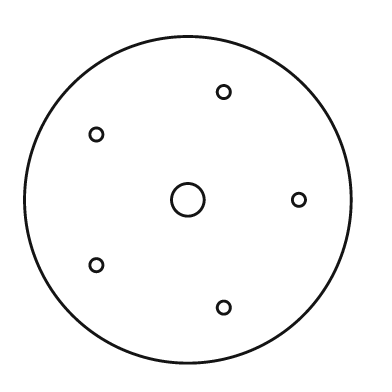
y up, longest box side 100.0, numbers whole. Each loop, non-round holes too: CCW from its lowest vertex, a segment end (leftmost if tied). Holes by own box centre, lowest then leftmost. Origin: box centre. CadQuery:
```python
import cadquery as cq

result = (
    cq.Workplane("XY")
    .moveTo(0.0, 0.0)
    .circle(50.0)
    .moveTo(11.0, -33.0)
    .circle(2.0)
    .moveTo(-28.0, -20.0)
    .circle(2.0)
    .moveTo(0.0, 0.0)
    .circle(5.0)
    .moveTo(34.0, 0.0)
    .circle(2.0)
    .moveTo(-28.0, 20.0)
    .circle(2.0)
    .moveTo(11.0, 33.0)
    .circle(2.0)
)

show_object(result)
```